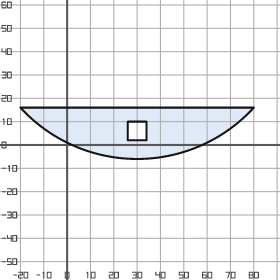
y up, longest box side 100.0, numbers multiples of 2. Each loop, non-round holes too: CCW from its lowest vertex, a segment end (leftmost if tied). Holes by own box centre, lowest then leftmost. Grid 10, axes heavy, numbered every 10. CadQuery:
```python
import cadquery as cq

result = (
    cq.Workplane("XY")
    .moveTo(-20.0, 16.0)
    .threePointArc((30.0, -6.0), (80.0, 16.0))
    .close()
    .moveTo(26.0, 2.0)
    .lineTo(34.0, 2.0)
    .lineTo(34.0, 10.0)
    .lineTo(26.0, 10.0)
    .close()
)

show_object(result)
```